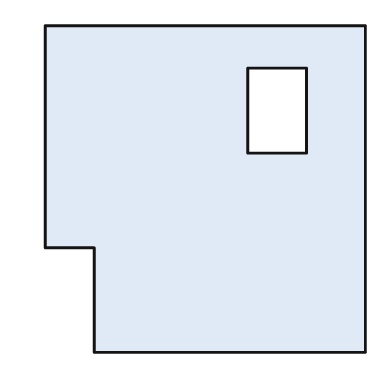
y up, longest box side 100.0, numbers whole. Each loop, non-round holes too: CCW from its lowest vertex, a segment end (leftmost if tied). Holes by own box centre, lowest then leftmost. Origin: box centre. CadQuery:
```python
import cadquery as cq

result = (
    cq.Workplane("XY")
    .moveTo(-34.0, -50.0)
    .lineTo(49.0, -50.0)
    .lineTo(49.0, 50.0)
    .lineTo(-49.0, 50.0)
    .lineTo(-49.0, -18.0)
    .lineTo(-34.0, -18.0)
    .close()
    .moveTo(13.0, 11.0)
    .lineTo(31.0, 11.0)
    .lineTo(31.0, 37.0)
    .lineTo(13.0, 37.0)
    .close()
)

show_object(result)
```